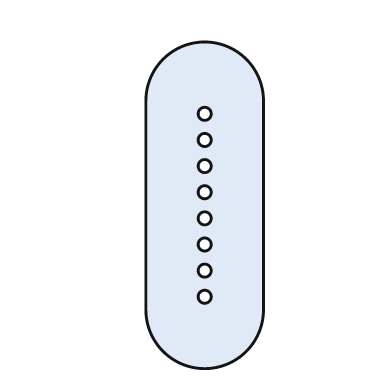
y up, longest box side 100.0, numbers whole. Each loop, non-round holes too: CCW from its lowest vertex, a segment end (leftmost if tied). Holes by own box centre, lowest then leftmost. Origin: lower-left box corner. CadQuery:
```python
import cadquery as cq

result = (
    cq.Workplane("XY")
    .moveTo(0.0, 18.0)
    .threePointArc((18.0, 0.0), (36.0, 18.0))
    .lineTo(36.0, 82.0)
    .threePointArc((18.0, 100.0), (0.0, 82.0))
    .close()
    .moveTo(18.0, 22.0)
    .circle(2.0)
    .moveTo(18.0, 30.0)
    .circle(2.0)
    .moveTo(18.0, 38.0)
    .circle(2.0)
    .moveTo(18.0, 46.0)
    .circle(2.0)
    .moveTo(18.0, 54.0)
    .circle(2.0)
    .moveTo(18.0, 62.0)
    .circle(2.0)
    .moveTo(18.0, 70.0)
    .circle(2.0)
    .moveTo(18.0, 78.0)
    .circle(2.0)
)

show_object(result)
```